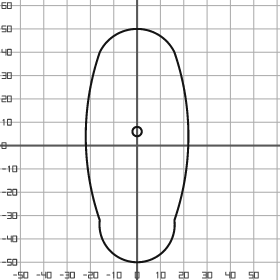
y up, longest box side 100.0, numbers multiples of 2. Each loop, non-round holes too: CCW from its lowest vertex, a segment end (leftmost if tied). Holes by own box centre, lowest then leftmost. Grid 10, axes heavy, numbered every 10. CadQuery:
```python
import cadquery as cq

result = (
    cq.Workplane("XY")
    .moveTo(-16.0, -32.0)
    .threePointArc((0.0, -50.0), (16.0, -32.0))
    .threePointArc((22.0, 4.0), (16.0, 40.0))
    .threePointArc((0.0, 50.0), (-16.0, 40.0))
    .threePointArc((-22.0, 4.0), (-16.0, -32.0))
    .close()
    .moveTo(0.0, 6.0)
    .circle(2.0)
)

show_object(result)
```